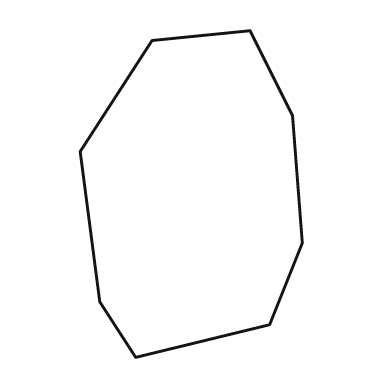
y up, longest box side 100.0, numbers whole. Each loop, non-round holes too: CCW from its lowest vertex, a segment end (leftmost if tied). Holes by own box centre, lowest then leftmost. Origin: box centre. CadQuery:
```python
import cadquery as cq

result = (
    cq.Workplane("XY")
    .moveTo(-17.0, -50.0)
    .lineTo(24.0, -40.0)
    .lineTo(34.0, -15.0)
    .lineTo(31.0, 24.0)
    .lineTo(18.0, 50.0)
    .lineTo(-12.0, 47.0)
    .lineTo(-34.0, 13.0)
    .lineTo(-28.0, -33.0)
    .close()
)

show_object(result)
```